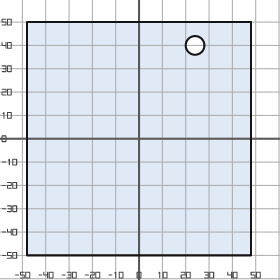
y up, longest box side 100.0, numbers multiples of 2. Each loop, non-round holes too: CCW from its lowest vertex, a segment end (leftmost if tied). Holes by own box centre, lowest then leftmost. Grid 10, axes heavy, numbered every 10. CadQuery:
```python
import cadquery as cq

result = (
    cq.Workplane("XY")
    .moveTo(-48.0, -50.0)
    .lineTo(48.0, -50.0)
    .lineTo(48.0, 50.0)
    .lineTo(-48.0, 50.0)
    .close()
    .moveTo(24.0, 40.0)
    .circle(4.0)
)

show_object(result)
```